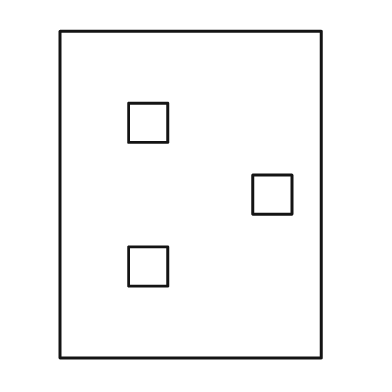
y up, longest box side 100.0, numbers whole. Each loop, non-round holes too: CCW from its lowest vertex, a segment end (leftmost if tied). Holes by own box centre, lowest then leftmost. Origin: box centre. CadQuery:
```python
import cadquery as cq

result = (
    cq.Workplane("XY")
    .moveTo(-40.0, -50.0)
    .lineTo(40.0, -50.0)
    .lineTo(40.0, 50.0)
    .lineTo(-40.0, 50.0)
    .close()
    .moveTo(-19.0, -28.0)
    .lineTo(-7.0, -28.0)
    .lineTo(-7.0, -16.0)
    .lineTo(-19.0, -16.0)
    .close()
    .moveTo(19.0, -6.0)
    .lineTo(31.0, -6.0)
    .lineTo(31.0, 6.0)
    .lineTo(19.0, 6.0)
    .close()
    .moveTo(-19.0, 16.0)
    .lineTo(-7.0, 16.0)
    .lineTo(-7.0, 28.0)
    .lineTo(-19.0, 28.0)
    .close()
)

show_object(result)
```